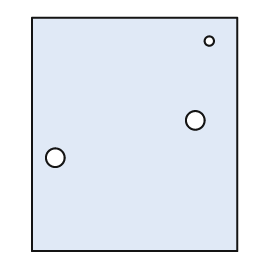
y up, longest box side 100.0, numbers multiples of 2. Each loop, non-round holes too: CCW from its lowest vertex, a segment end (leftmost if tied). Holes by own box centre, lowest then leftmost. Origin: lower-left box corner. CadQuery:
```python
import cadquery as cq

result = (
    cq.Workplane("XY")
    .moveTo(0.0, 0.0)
    .lineTo(88.0, 0.0)
    .lineTo(88.0, 100.0)
    .lineTo(0.0, 100.0)
    .close()
    .moveTo(10.0, 40.0)
    .circle(4.0)
    .moveTo(70.0, 56.0)
    .circle(4.0)
    .moveTo(76.0, 90.0)
    .circle(2.0)
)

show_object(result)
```